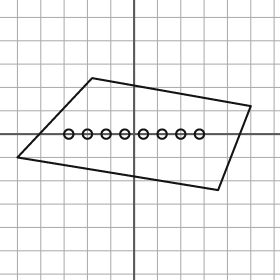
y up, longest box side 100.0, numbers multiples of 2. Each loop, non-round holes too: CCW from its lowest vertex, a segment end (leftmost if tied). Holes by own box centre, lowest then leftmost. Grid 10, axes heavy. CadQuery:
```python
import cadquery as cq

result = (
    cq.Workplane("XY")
    .moveTo(36.0, -24.0)
    .lineTo(50.0, 12.0)
    .lineTo(-18.0, 24.0)
    .lineTo(-50.0, -10.0)
    .close()
    .moveTo(-28.0, 0.0)
    .circle(2.0)
    .moveTo(-20.0, 0.0)
    .circle(2.0)
    .moveTo(-12.0, 0.0)
    .circle(2.0)
    .moveTo(-4.0, 0.0)
    .circle(2.0)
    .moveTo(4.0, 0.0)
    .circle(2.0)
    .moveTo(12.0, 0.0)
    .circle(2.0)
    .moveTo(20.0, 0.0)
    .circle(2.0)
    .moveTo(28.0, 0.0)
    .circle(2.0)
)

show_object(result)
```